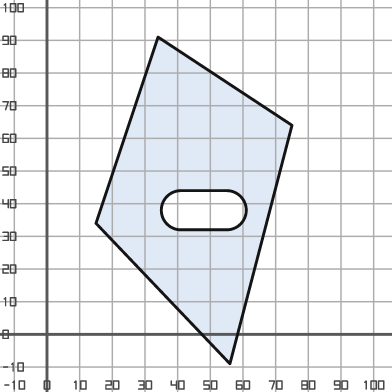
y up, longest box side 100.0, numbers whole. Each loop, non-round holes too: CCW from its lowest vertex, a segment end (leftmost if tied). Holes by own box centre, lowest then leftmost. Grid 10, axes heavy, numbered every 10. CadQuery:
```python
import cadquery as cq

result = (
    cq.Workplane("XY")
    .moveTo(56.0, -9.0)
    .lineTo(75.0, 64.0)
    .lineTo(34.0, 91.0)
    .lineTo(15.0, 34.0)
    .close()
    .moveTo(41.0, 32.0)
    .lineTo(55.0, 32.0)
    .threePointArc((61.0, 38.0), (55.0, 44.0))
    .lineTo(41.0, 44.0)
    .threePointArc((35.0, 38.0), (41.0, 32.0))
    .close()
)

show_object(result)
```